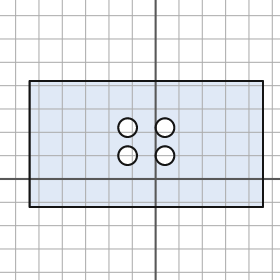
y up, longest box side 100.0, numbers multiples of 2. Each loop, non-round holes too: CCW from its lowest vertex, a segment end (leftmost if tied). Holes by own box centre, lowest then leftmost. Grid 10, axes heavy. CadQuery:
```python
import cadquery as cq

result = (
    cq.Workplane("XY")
    .moveTo(-54.0, -12.0)
    .lineTo(46.0, -12.0)
    .lineTo(46.0, 42.0)
    .lineTo(-54.0, 42.0)
    .close()
    .moveTo(-12.0, 10.0)
    .circle(4.0)
    .moveTo(4.0, 10.0)
    .circle(4.0)
    .moveTo(-12.0, 22.0)
    .circle(4.0)
    .moveTo(4.0, 22.0)
    .circle(4.0)
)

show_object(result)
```